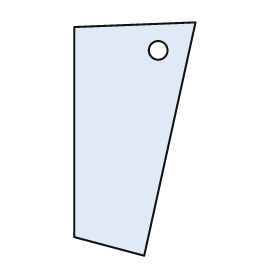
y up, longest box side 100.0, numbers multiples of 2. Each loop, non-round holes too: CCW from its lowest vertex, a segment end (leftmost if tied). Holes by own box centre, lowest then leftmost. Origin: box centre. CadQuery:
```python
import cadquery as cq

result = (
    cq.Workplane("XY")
    .moveTo(4.0, -50.0)
    .lineTo(26.0, 50.0)
    .lineTo(-26.0, 48.0)
    .lineTo(-26.0, -42.0)
    .close()
    .moveTo(10.0, 38.0)
    .circle(4.0)
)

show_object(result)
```